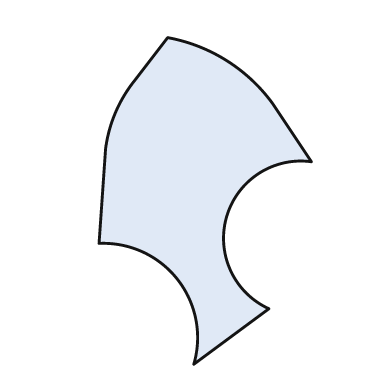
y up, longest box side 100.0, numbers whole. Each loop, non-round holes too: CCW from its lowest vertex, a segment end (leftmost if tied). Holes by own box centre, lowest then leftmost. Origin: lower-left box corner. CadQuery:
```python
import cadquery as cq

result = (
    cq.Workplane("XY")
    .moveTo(29.0, 0.0)
    .lineTo(52.0, 17.0)
    .threePointArc((39.0, 45.0), (65.0, 62.0))
    .lineTo(53.0, 80.0)
    .threePointArc((39.0, 93.0), (21.0, 100.0))
    .lineTo(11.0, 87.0)
    .threePointArc((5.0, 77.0), (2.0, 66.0))
    .lineTo(0.0, 37.0)
    .threePointArc((24.0, 26.0), (29.0, 0.0))
    .close()
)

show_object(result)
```